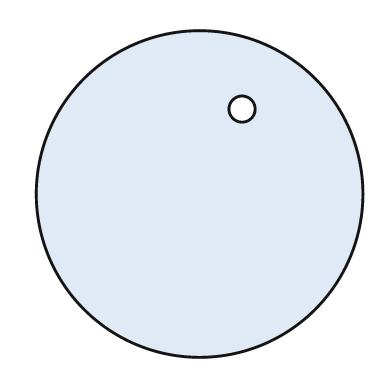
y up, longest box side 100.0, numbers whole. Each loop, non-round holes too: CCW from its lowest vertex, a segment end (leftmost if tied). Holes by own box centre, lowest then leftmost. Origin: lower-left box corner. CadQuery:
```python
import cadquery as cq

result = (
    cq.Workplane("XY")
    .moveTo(50.0, 50.0)
    .circle(50.0)
    .moveTo(63.0, 76.0)
    .circle(4.0)
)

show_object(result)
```